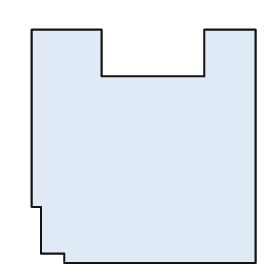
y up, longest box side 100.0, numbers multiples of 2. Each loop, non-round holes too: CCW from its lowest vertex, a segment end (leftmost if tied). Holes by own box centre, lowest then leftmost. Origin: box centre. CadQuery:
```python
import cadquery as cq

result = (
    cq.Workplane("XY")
    .moveTo(-34.0, -50.0)
    .lineTo(48.0, -50.0)
    .lineTo(48.0, 50.0)
    .lineTo(26.0, 50.0)
    .lineTo(26.0, 30.0)
    .lineTo(-18.0, 30.0)
    .lineTo(-18.0, 50.0)
    .lineTo(-48.0, 50.0)
    .lineTo(-48.0, -26.0)
    .lineTo(-44.0, -26.0)
    .lineTo(-44.0, -46.0)
    .lineTo(-34.0, -46.0)
    .close()
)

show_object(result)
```